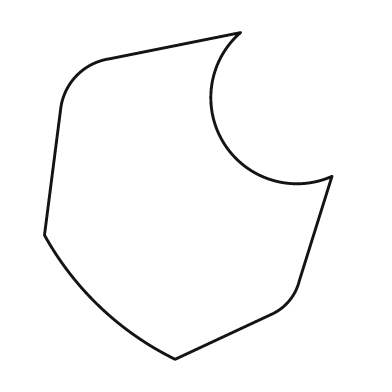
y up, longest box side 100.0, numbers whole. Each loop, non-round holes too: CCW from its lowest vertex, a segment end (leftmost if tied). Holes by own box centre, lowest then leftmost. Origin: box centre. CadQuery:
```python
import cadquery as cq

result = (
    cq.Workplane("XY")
    .moveTo(-4.0, -50.0)
    .lineTo(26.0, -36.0)
    .threePointArc((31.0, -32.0), (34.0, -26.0))
    .lineTo(44.0, 6.0)
    .threePointArc((11.0, 16.0), (16.0, 50.0))
    .lineTo(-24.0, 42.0)
    .threePointArc((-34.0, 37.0), (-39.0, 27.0))
    .lineTo(-44.0, -12.0)
    .threePointArc((-27.0, -34.0), (-4.0, -50.0))
    .close()
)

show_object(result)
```